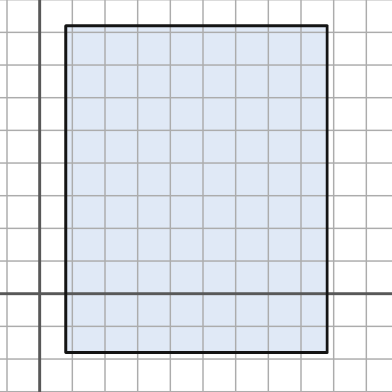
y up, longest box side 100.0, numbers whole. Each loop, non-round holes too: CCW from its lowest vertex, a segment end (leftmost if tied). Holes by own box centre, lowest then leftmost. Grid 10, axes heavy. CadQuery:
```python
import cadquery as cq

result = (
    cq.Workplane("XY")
    .moveTo(8.0, -18.0)
    .lineTo(88.0, -18.0)
    .lineTo(88.0, 82.0)
    .lineTo(8.0, 82.0)
    .close()
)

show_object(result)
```